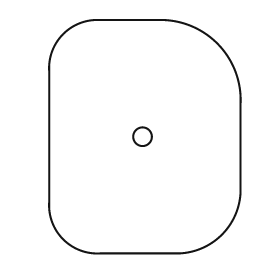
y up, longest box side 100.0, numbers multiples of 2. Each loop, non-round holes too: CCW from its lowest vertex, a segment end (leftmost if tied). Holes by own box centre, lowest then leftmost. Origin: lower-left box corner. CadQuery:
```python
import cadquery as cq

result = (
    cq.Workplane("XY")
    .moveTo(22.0, 0.0)
    .lineTo(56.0, 0.0)
    .threePointArc((74.0, 8.0), (82.0, 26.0))
    .lineTo(82.0, 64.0)
    .threePointArc((72.0, 90.0), (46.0, 100.0))
    .lineTo(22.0, 100.0)
    .threePointArc((6.0, 94.0), (0.0, 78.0))
    .lineTo(0.0, 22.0)
    .threePointArc((6.0, 6.0), (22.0, 0.0))
    .close()
    .moveTo(40.0, 50.0)
    .circle(4.0)
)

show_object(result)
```